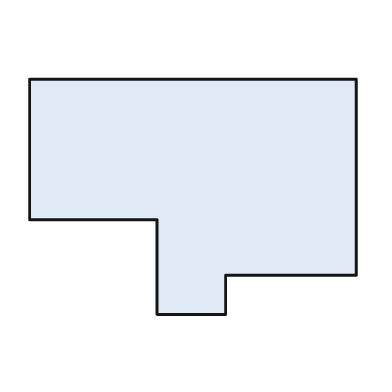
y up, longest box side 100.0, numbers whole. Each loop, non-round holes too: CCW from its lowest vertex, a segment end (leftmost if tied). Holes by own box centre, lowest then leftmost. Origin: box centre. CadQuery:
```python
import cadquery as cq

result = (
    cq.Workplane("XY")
    .moveTo(-11.0, -36.0)
    .lineTo(10.0, -36.0)
    .lineTo(10.0, -24.0)
    .lineTo(50.0, -24.0)
    .lineTo(50.0, 36.0)
    .lineTo(-50.0, 36.0)
    .lineTo(-50.0, -7.0)
    .lineTo(-11.0, -7.0)
    .close()
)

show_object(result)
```